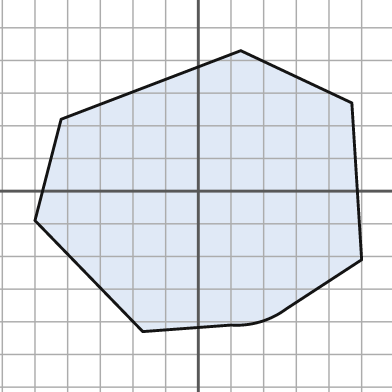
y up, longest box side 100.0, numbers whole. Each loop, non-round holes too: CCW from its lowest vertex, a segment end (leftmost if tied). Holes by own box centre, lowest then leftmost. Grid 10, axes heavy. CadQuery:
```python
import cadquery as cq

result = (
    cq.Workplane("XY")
    .moveTo(-17.0, -43.0)
    .lineTo(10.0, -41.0)
    .threePointArc((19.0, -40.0), (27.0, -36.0))
    .lineTo(50.0, -21.0)
    .lineTo(47.0, 27.0)
    .lineTo(13.0, 43.0)
    .lineTo(-42.0, 22.0)
    .lineTo(-50.0, -9.0)
    .close()
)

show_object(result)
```